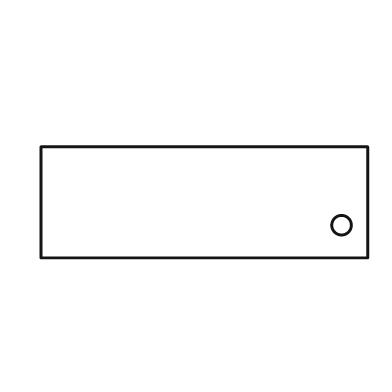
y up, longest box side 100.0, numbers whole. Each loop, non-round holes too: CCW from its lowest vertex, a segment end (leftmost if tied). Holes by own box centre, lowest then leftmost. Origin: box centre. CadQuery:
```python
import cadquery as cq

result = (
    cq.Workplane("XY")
    .moveTo(-50.0, -17.0)
    .lineTo(50.0, -17.0)
    .lineTo(50.0, 17.0)
    .lineTo(-50.0, 17.0)
    .close()
    .moveTo(42.0, -7.0)
    .circle(3.0)
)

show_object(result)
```